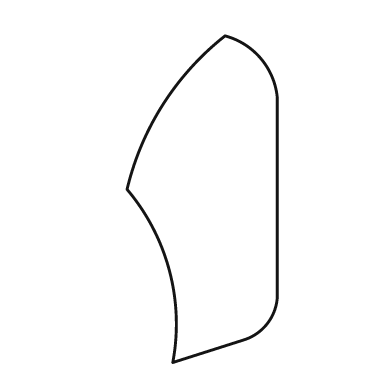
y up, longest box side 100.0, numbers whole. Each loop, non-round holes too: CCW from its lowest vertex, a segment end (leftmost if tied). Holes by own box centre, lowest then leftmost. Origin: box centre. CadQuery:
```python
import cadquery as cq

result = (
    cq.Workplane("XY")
    .moveTo(-9.0, -50.0)
    .lineTo(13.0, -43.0)
    .threePointArc((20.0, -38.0), (23.0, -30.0))
    .lineTo(23.0, 31.0)
    .threePointArc((18.0, 43.0), (7.0, 50.0))
    .threePointArc((-12.0, 29.0), (-23.0, 3.0))
    .threePointArc((-10.0, -22.0), (-9.0, -50.0))
    .close()
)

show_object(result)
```